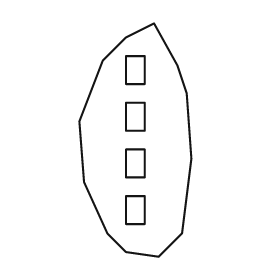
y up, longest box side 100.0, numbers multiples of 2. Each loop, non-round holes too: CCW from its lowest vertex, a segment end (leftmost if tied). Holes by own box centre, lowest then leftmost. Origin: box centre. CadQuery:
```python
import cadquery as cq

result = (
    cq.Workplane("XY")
    .moveTo(10.0, -50.0)
    .lineTo(20.0, -40.0)
    .lineTo(24.0, -8.0)
    .lineTo(22.0, 20.0)
    .lineTo(18.0, 32.0)
    .lineTo(8.0, 50.0)
    .lineTo(-4.0, 44.0)
    .lineTo(-14.0, 34.0)
    .lineTo(-24.0, 8.0)
    .lineTo(-22.0, -18.0)
    .lineTo(-12.0, -40.0)
    .lineTo(-4.0, -48.0)
    .close()
    .moveTo(-4.0, -36.0)
    .lineTo(4.0, -36.0)
    .lineTo(4.0, -24.0)
    .lineTo(-4.0, -24.0)
    .close()
    .moveTo(-4.0, -16.0)
    .lineTo(4.0, -16.0)
    .lineTo(4.0, -4.0)
    .lineTo(-4.0, -4.0)
    .close()
    .moveTo(-4.0, 4.0)
    .lineTo(4.0, 4.0)
    .lineTo(4.0, 16.0)
    .lineTo(-4.0, 16.0)
    .close()
    .moveTo(-4.0, 24.0)
    .lineTo(4.0, 24.0)
    .lineTo(4.0, 36.0)
    .lineTo(-4.0, 36.0)
    .close()
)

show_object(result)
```